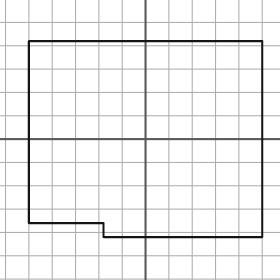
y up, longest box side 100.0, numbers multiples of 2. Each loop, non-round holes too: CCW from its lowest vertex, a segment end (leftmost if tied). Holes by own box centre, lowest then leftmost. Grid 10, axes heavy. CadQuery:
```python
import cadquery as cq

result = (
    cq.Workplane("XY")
    .moveTo(-18.0, -42.0)
    .lineTo(50.0, -42.0)
    .lineTo(50.0, 42.0)
    .lineTo(-50.0, 42.0)
    .lineTo(-50.0, -36.0)
    .lineTo(-18.0, -36.0)
    .close()
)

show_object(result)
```